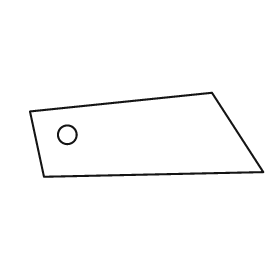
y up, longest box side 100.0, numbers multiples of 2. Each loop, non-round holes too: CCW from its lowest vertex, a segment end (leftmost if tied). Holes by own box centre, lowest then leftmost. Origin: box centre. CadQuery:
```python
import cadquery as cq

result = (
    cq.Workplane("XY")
    .moveTo(-44.0, -18.0)
    .lineTo(50.0, -16.0)
    .lineTo(28.0, 18.0)
    .lineTo(-50.0, 10.0)
    .close()
    .moveTo(-34.0, 0.0)
    .circle(4.0)
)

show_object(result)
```